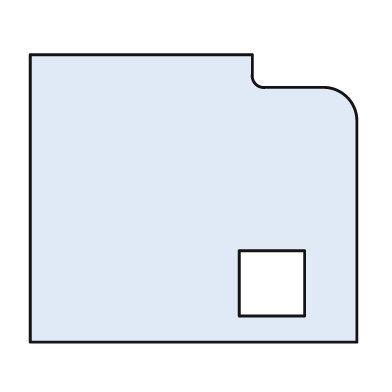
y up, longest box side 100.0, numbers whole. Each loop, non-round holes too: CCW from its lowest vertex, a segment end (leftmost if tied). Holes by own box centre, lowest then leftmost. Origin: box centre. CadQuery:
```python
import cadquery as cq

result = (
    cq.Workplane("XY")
    .moveTo(-50.0, -44.0)
    .lineTo(50.0, -44.0)
    .lineTo(50.0, 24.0)
    .threePointArc((47.0, 31.0), (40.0, 34.0))
    .lineTo(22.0, 34.0)
    .threePointArc((19.0, 35.0), (18.0, 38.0))
    .lineTo(18.0, 44.0)
    .lineTo(-50.0, 44.0)
    .close()
    .moveTo(14.0, -36.0)
    .lineTo(34.0, -36.0)
    .lineTo(34.0, -16.0)
    .lineTo(14.0, -16.0)
    .close()
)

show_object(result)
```